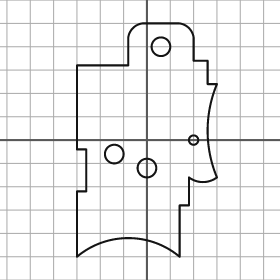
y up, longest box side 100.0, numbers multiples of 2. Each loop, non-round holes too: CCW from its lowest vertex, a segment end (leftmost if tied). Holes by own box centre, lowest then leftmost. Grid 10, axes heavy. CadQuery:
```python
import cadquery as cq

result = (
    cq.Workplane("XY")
    .moveTo(-30.0, -50.0)
    .threePointArc((-8.0, -42.0), (14.0, -50.0))
    .lineTo(14.0, -28.0)
    .lineTo(18.0, -28.0)
    .lineTo(18.0, -16.0)
    .threePointArc((24.0, -18.0), (30.0, -16.0))
    .threePointArc((26.0, 4.0), (30.0, 24.0))
    .lineTo(26.0, 24.0)
    .lineTo(26.0, 34.0)
    .lineTo(20.0, 34.0)
    .lineTo(20.0, 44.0)
    .threePointArc((18.0, 48.0), (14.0, 50.0))
    .lineTo(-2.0, 50.0)
    .threePointArc((-6.0, 48.0), (-8.0, 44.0))
    .lineTo(-8.0, 32.0)
    .lineTo(-30.0, 32.0)
    .lineTo(-30.0, -4.0)
    .lineTo(-26.0, -4.0)
    .lineTo(-26.0, -22.0)
    .lineTo(-30.0, -22.0)
    .close()
    .moveTo(0.0, -12.0)
    .circle(4.0)
    .moveTo(-14.0, -6.0)
    .circle(4.0)
    .moveTo(20.0, 0.0)
    .circle(2.0)
    .moveTo(6.0, 40.0)
    .circle(4.0)
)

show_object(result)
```